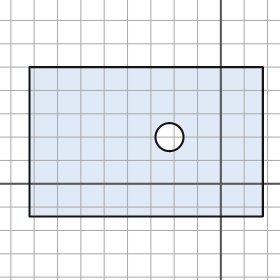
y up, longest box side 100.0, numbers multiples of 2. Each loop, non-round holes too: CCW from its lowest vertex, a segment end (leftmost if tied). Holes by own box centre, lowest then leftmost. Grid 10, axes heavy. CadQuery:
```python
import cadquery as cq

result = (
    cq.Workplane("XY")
    .moveTo(-82.0, -14.0)
    .lineTo(18.0, -14.0)
    .lineTo(18.0, 50.0)
    .lineTo(-82.0, 50.0)
    .close()
    .moveTo(-22.0, 20.0)
    .circle(6.0)
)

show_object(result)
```